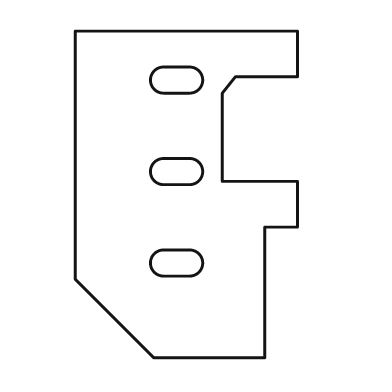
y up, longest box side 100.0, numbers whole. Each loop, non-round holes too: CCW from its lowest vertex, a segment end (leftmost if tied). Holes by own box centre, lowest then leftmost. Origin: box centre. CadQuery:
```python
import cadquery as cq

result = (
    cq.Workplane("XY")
    .moveTo(-10.0, -50.0)
    .lineTo(24.0, -50.0)
    .lineTo(24.0, -10.0)
    .lineTo(34.0, -10.0)
    .lineTo(34.0, 4.0)
    .lineTo(11.0, 4.0)
    .lineTo(11.0, 31.0)
    .lineTo(15.0, 36.0)
    .lineTo(34.0, 36.0)
    .lineTo(34.0, 50.0)
    .lineTo(-34.0, 50.0)
    .lineTo(-34.0, -26.0)
    .close()
    .moveTo(-7.0, -25.0)
    .lineTo(1.0, -25.0)
    .threePointArc((5.0, -21.0), (1.0, -17.0))
    .lineTo(-7.0, -17.0)
    .threePointArc((-11.0, -21.0), (-7.0, -25.0))
    .close()
    .moveTo(-7.0, 3.0)
    .lineTo(1.0, 3.0)
    .threePointArc((5.0, 7.0), (1.0, 11.0))
    .lineTo(-7.0, 11.0)
    .threePointArc((-11.0, 7.0), (-7.0, 3.0))
    .close()
    .moveTo(-7.0, 31.0)
    .lineTo(1.0, 31.0)
    .threePointArc((5.0, 35.0), (1.0, 39.0))
    .lineTo(-7.0, 39.0)
    .threePointArc((-11.0, 35.0), (-7.0, 31.0))
    .close()
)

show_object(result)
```